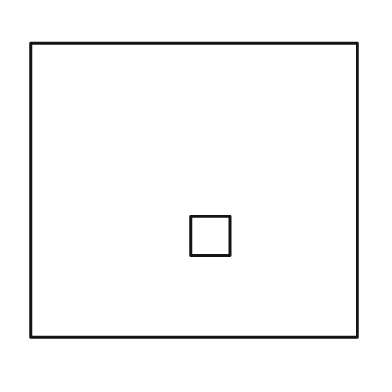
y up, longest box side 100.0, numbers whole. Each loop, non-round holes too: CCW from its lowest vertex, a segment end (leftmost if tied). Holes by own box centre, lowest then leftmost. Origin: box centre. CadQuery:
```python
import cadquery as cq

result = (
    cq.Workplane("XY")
    .moveTo(-50.0, -45.0)
    .lineTo(50.0, -45.0)
    .lineTo(50.0, 45.0)
    .lineTo(-50.0, 45.0)
    .close()
    .moveTo(-1.0, -20.0)
    .lineTo(11.0, -20.0)
    .lineTo(11.0, -8.0)
    .lineTo(-1.0, -8.0)
    .close()
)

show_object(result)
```